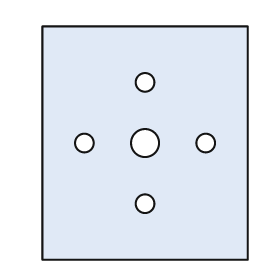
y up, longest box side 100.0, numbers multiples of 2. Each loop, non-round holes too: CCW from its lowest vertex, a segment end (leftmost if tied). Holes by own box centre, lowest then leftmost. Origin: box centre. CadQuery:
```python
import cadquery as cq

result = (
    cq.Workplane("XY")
    .moveTo(-44.0, -50.0)
    .lineTo(44.0, -50.0)
    .lineTo(44.0, 50.0)
    .lineTo(-44.0, 50.0)
    .close()
    .moveTo(0.0, -26.0)
    .circle(4.0)
    .moveTo(-26.0, 0.0)
    .circle(4.0)
    .moveTo(0.0, 0.0)
    .circle(6.0)
    .moveTo(26.0, 0.0)
    .circle(4.0)
    .moveTo(0.0, 26.0)
    .circle(4.0)
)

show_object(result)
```